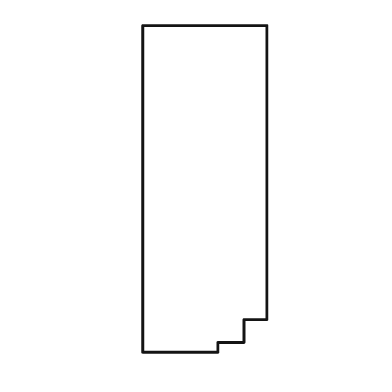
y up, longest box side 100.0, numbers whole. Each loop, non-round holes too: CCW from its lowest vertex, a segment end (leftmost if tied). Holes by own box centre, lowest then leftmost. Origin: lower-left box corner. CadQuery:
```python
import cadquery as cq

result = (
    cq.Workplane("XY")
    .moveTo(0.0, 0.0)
    .lineTo(23.0, 0.0)
    .lineTo(23.0, 3.0)
    .lineTo(31.0, 3.0)
    .lineTo(31.0, 10.0)
    .lineTo(38.0, 10.0)
    .lineTo(38.0, 100.0)
    .lineTo(0.0, 100.0)
    .close()
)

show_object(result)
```